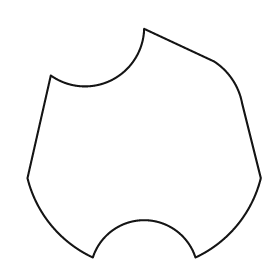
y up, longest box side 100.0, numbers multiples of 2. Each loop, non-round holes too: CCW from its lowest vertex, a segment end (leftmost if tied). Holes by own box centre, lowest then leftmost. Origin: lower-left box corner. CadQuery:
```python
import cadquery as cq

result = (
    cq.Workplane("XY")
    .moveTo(28.0, 0.0)
    .threePointArc((50.0, 16.0), (72.0, 0.0))
    .threePointArc((90.0, 14.0), (100.0, 34.0))
    .lineTo(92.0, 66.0)
    .threePointArc((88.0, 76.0), (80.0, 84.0))
    .lineTo(50.0, 98.0)
    .threePointArc((36.0, 76.0), (10.0, 78.0))
    .lineTo(0.0, 34.0)
    .threePointArc((10.0, 14.0), (28.0, 0.0))
    .close()
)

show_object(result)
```